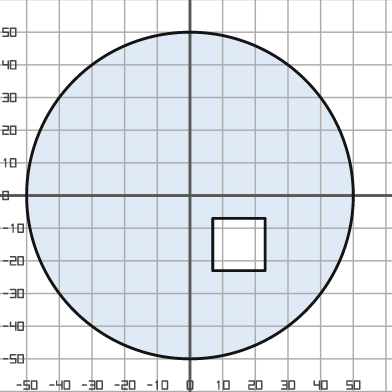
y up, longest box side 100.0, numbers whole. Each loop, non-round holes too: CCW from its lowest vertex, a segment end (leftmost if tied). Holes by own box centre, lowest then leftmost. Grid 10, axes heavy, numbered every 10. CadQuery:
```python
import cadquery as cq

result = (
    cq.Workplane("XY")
    .moveTo(0.0, 0.0)
    .circle(50.0)
    .moveTo(7.0, -23.0)
    .lineTo(23.0, -23.0)
    .lineTo(23.0, -7.0)
    .lineTo(7.0, -7.0)
    .close()
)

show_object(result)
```